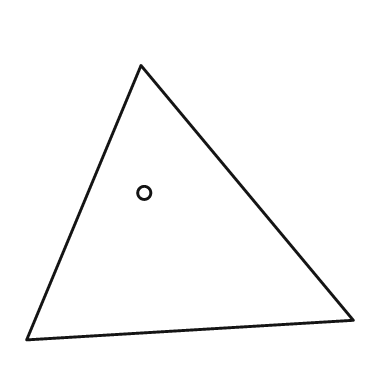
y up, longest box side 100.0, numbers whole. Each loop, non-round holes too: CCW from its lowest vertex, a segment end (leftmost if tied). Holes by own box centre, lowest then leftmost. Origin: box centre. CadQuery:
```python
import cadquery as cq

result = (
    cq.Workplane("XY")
    .moveTo(-50.0, -42.0)
    .lineTo(50.0, -36.0)
    .lineTo(-15.0, 42.0)
    .close()
    .moveTo(-14.0, 3.0)
    .circle(2.0)
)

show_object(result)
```